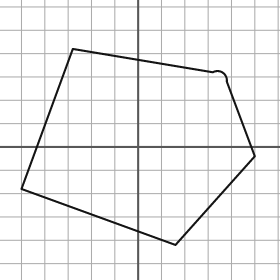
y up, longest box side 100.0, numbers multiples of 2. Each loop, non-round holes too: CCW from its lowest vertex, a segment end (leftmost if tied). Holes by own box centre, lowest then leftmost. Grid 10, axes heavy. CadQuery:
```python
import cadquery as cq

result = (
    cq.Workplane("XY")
    .moveTo(16.0, -42.0)
    .lineTo(50.0, -4.0)
    .lineTo(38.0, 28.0)
    .threePointArc((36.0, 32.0), (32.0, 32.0))
    .lineTo(-28.0, 42.0)
    .lineTo(-50.0, -18.0)
    .close()
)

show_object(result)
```